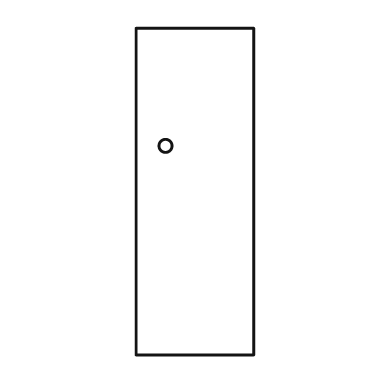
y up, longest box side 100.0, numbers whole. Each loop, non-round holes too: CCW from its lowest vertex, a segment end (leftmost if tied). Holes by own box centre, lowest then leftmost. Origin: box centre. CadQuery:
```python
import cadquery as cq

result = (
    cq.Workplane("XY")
    .moveTo(-18.0, -50.0)
    .lineTo(18.0, -50.0)
    .lineTo(18.0, 50.0)
    .lineTo(-18.0, 50.0)
    .close()
    .moveTo(-9.0, 14.0)
    .circle(2.0)
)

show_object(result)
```